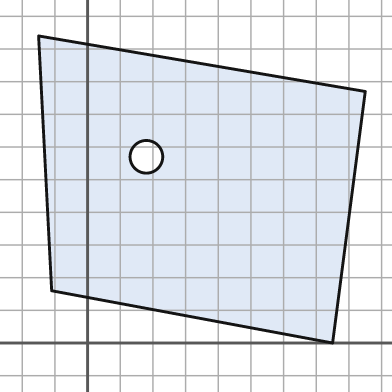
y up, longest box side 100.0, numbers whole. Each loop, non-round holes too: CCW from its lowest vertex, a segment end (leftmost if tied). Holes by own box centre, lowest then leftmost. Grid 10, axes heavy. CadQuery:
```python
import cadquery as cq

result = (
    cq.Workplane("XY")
    .moveTo(75.0, 0.0)
    .lineTo(85.0, 77.0)
    .lineTo(-15.0, 94.0)
    .lineTo(-11.0, 16.0)
    .close()
    .moveTo(18.0, 57.0)
    .circle(5.0)
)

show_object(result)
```